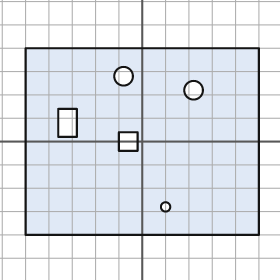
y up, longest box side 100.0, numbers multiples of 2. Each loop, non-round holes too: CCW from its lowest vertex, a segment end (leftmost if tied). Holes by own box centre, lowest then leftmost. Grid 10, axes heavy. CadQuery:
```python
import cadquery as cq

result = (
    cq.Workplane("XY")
    .moveTo(-50.0, -40.0)
    .lineTo(50.0, -40.0)
    .lineTo(50.0, 40.0)
    .lineTo(-50.0, 40.0)
    .close()
    .moveTo(10.0, -28.0)
    .circle(2.0)
    .moveTo(-10.0, -4.0)
    .lineTo(-2.0, -4.0)
    .lineTo(-2.0, 4.0)
    .lineTo(-10.0, 4.0)
    .close()
    .moveTo(-36.0, 2.0)
    .lineTo(-28.0, 2.0)
    .lineTo(-28.0, 14.0)
    .lineTo(-36.0, 14.0)
    .close()
    .moveTo(22.0, 22.0)
    .circle(4.0)
    .moveTo(-8.0, 28.0)
    .circle(4.0)
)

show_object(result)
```